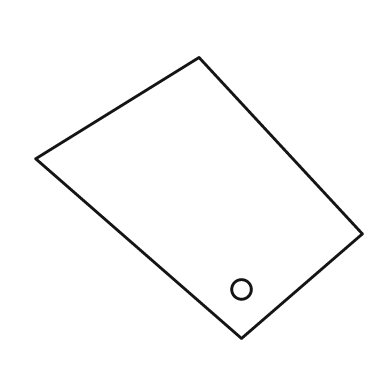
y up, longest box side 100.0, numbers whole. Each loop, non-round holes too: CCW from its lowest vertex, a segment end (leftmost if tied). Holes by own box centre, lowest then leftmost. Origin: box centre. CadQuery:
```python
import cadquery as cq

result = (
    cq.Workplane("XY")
    .moveTo(13.0, -43.0)
    .lineTo(50.0, -11.0)
    .lineTo(0.0, 43.0)
    .lineTo(-50.0, 12.0)
    .close()
    .moveTo(13.0, -28.0)
    .circle(3.0)
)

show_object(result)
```